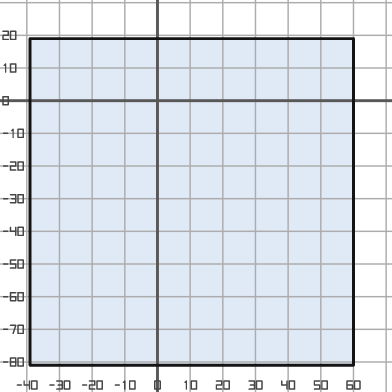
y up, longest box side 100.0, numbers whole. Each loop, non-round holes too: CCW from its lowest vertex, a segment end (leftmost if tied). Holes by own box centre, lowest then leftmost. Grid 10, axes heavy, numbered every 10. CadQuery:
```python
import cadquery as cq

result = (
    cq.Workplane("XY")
    .moveTo(-39.0, -81.0)
    .lineTo(60.0, -81.0)
    .lineTo(60.0, 19.0)
    .lineTo(-39.0, 19.0)
    .close()
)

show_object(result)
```